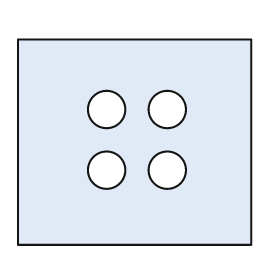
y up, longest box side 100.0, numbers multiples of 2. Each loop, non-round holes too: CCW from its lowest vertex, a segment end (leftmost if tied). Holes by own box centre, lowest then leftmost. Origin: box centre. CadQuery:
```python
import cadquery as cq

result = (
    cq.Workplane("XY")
    .moveTo(-50.0, -44.0)
    .lineTo(50.0, -44.0)
    .lineTo(50.0, 44.0)
    .lineTo(-50.0, 44.0)
    .close()
    .moveTo(-12.0, -12.0)
    .circle(8.0)
    .moveTo(14.0, -12.0)
    .circle(8.0)
    .moveTo(-12.0, 14.0)
    .circle(8.0)
    .moveTo(14.0, 14.0)
    .circle(8.0)
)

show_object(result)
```